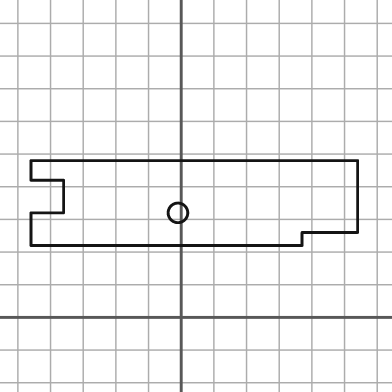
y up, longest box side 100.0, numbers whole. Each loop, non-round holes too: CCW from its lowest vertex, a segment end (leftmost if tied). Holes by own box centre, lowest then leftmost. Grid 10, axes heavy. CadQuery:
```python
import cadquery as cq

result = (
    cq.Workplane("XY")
    .moveTo(-46.0, 22.0)
    .lineTo(37.0, 22.0)
    .lineTo(37.0, 26.0)
    .lineTo(54.0, 26.0)
    .lineTo(54.0, 48.0)
    .lineTo(-46.0, 48.0)
    .lineTo(-46.0, 42.0)
    .lineTo(-36.0, 42.0)
    .lineTo(-36.0, 32.0)
    .lineTo(-46.0, 32.0)
    .close()
    .moveTo(-1.0, 32.0)
    .circle(3.0)
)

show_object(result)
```